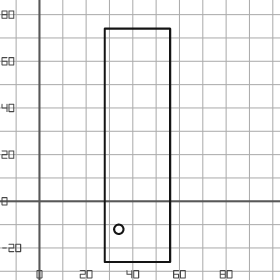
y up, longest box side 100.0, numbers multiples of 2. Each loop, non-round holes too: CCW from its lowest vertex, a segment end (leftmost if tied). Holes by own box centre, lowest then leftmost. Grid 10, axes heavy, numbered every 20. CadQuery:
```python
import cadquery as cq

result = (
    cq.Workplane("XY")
    .moveTo(28.0, -26.0)
    .lineTo(56.0, -26.0)
    .lineTo(56.0, 74.0)
    .lineTo(28.0, 74.0)
    .close()
    .moveTo(34.0, -12.0)
    .circle(2.0)
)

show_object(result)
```